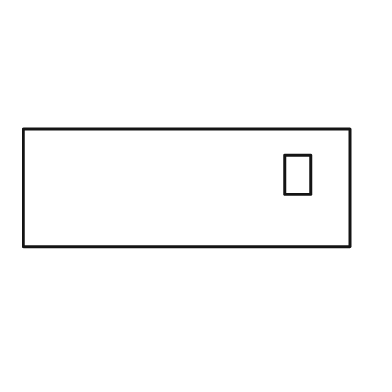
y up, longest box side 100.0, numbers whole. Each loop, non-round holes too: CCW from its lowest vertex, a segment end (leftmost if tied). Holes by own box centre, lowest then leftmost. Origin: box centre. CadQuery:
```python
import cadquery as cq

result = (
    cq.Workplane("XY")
    .moveTo(-50.0, -18.0)
    .lineTo(50.0, -18.0)
    .lineTo(50.0, 18.0)
    .lineTo(-50.0, 18.0)
    .close()
    .moveTo(30.0, -2.0)
    .lineTo(38.0, -2.0)
    .lineTo(38.0, 10.0)
    .lineTo(30.0, 10.0)
    .close()
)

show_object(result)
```